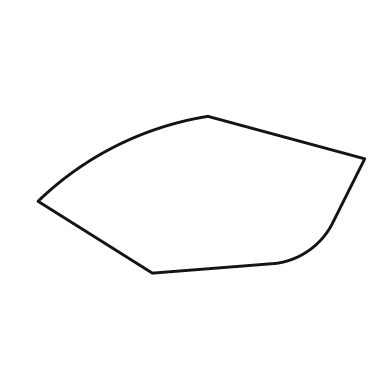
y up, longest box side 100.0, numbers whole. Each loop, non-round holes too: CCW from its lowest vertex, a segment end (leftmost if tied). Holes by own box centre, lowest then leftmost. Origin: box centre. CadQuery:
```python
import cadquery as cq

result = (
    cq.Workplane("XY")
    .moveTo(-15.0, -24.0)
    .lineTo(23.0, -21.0)
    .threePointArc((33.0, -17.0), (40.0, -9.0))
    .lineTo(50.0, 11.0)
    .lineTo(2.0, 24.0)
    .threePointArc((-26.0, 15.0), (-50.0, -2.0))
    .close()
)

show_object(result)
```